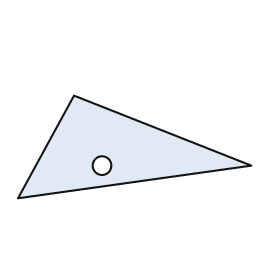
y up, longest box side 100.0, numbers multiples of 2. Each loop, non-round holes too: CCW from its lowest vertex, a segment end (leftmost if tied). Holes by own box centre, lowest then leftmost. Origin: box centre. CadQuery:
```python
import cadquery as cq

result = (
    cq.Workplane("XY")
    .moveTo(-50.0, -22.0)
    .lineTo(50.0, -8.0)
    .lineTo(-26.0, 22.0)
    .close()
    .moveTo(-14.0, -8.0)
    .circle(4.0)
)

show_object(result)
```